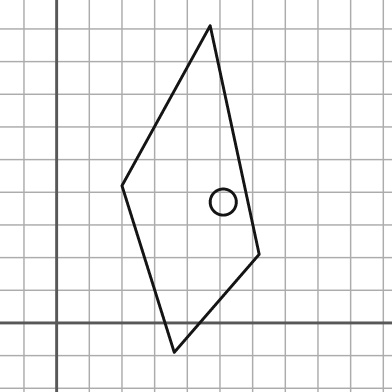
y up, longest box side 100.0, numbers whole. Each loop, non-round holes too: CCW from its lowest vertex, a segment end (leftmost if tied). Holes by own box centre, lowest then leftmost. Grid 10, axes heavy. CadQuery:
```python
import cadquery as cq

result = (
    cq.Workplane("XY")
    .moveTo(36.0, -9.0)
    .lineTo(62.0, 21.0)
    .lineTo(47.0, 91.0)
    .lineTo(20.0, 42.0)
    .close()
    .moveTo(51.0, 37.0)
    .circle(4.0)
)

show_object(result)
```